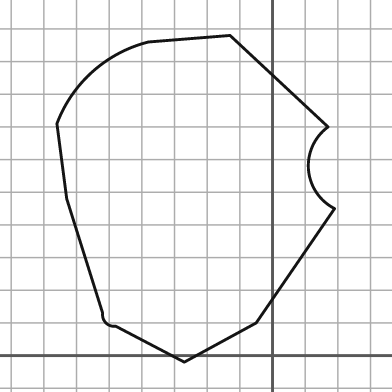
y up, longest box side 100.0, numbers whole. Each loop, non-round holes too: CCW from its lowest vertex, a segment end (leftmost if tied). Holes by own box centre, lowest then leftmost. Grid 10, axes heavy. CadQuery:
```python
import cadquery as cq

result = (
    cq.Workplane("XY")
    .moveTo(-27.0, -2.0)
    .lineTo(-5.0, 10.0)
    .lineTo(19.0, 45.0)
    .threePointArc((11.0, 57.0), (17.0, 70.0))
    .lineTo(-13.0, 98.0)
    .lineTo(-38.0, 96.0)
    .threePointArc((-55.0, 87.0), (-66.0, 71.0))
    .lineTo(-63.0, 48.0)
    .lineTo(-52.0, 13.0)
    .threePointArc((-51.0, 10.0), (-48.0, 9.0))
    .close()
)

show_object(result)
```